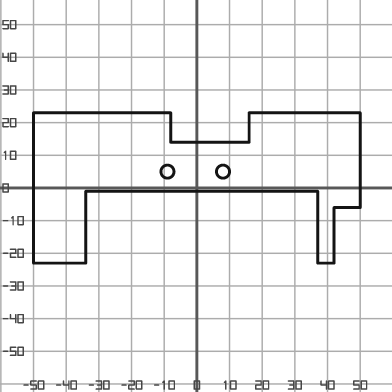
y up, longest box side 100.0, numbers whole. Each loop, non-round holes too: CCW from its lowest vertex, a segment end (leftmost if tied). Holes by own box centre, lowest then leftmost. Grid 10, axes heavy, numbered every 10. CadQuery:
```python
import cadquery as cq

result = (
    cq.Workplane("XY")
    .moveTo(-50.0, -23.0)
    .lineTo(-34.0, -23.0)
    .lineTo(-34.0, -1.0)
    .lineTo(37.0, -1.0)
    .lineTo(37.0, -23.0)
    .lineTo(42.0, -23.0)
    .lineTo(42.0, -6.0)
    .lineTo(50.0, -6.0)
    .lineTo(50.0, 23.0)
    .lineTo(16.0, 23.0)
    .lineTo(16.0, 14.0)
    .lineTo(-8.0, 14.0)
    .lineTo(-8.0, 23.0)
    .lineTo(-50.0, 23.0)
    .close()
    .moveTo(-9.0, 5.0)
    .circle(2.0)
    .moveTo(8.0, 5.0)
    .circle(2.0)
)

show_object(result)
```